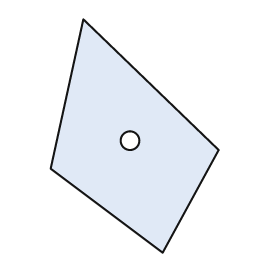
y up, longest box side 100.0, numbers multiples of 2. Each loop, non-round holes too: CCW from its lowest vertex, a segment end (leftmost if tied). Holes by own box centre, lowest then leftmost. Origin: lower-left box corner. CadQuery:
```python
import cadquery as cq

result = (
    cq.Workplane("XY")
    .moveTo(48.0, 0.0)
    .lineTo(72.0, 44.0)
    .lineTo(14.0, 100.0)
    .lineTo(0.0, 36.0)
    .close()
    .moveTo(34.0, 48.0)
    .circle(4.0)
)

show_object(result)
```